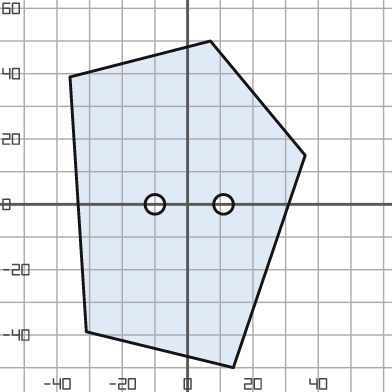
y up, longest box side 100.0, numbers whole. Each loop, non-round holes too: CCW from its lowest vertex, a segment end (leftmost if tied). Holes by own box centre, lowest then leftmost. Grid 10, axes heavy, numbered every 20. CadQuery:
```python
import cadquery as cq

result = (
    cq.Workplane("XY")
    .moveTo(14.0, -50.0)
    .lineTo(36.0, 15.0)
    .lineTo(7.0, 50.0)
    .lineTo(-36.0, 39.0)
    .lineTo(-31.0, -39.0)
    .close()
    .moveTo(-10.0, 0.0)
    .circle(3.0)
    .moveTo(11.0, 0.0)
    .circle(3.0)
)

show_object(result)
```